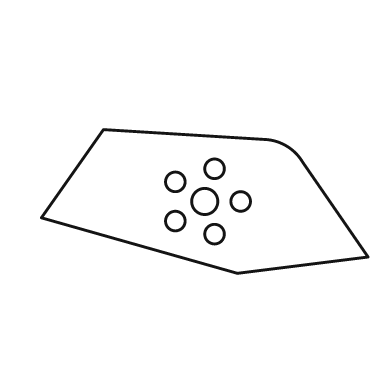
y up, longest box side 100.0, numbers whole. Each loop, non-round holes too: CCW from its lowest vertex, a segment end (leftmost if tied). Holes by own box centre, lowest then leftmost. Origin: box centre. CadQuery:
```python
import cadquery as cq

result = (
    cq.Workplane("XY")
    .moveTo(10.0, -22.0)
    .lineTo(50.0, -17.0)
    .lineTo(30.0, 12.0)
    .threePointArc((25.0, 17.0), (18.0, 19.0))
    .lineTo(-31.0, 22.0)
    .lineTo(-50.0, -5.0)
    .close()
    .moveTo(3.0, -10.0)
    .circle(3.0)
    .moveTo(-9.0, -6.0)
    .circle(3.0)
    .moveTo(0.0, 0.0)
    .circle(4.0)
    .moveTo(11.0, 0.0)
    .circle(3.0)
    .moveTo(-9.0, 6.0)
    .circle(3.0)
    .moveTo(3.0, 10.0)
    .circle(3.0)
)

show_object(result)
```